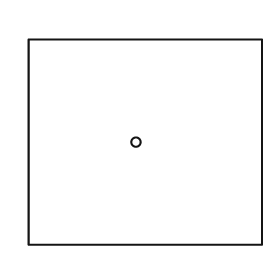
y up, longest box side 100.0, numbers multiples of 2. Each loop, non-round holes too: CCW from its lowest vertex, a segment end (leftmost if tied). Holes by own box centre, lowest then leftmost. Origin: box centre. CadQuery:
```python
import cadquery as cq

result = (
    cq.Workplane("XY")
    .moveTo(-50.0, -44.0)
    .lineTo(50.0, -44.0)
    .lineTo(50.0, 44.0)
    .lineTo(-50.0, 44.0)
    .close()
    .moveTo(-4.0, 0.0)
    .circle(2.0)
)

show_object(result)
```